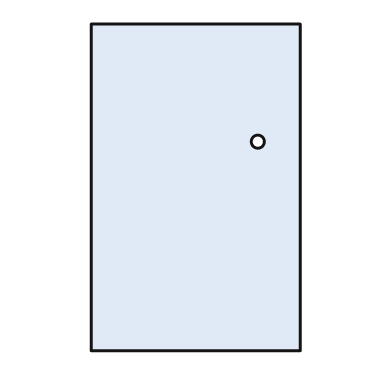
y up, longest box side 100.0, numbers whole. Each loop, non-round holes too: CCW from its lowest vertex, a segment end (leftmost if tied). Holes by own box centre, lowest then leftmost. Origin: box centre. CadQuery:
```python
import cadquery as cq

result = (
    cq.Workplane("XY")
    .moveTo(-32.0, -50.0)
    .lineTo(32.0, -50.0)
    .lineTo(32.0, 50.0)
    .lineTo(-32.0, 50.0)
    .close()
    .moveTo(19.0, 14.0)
    .circle(2.0)
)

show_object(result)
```